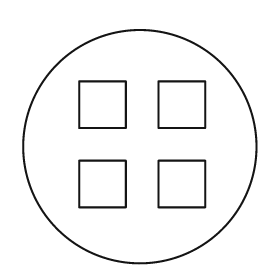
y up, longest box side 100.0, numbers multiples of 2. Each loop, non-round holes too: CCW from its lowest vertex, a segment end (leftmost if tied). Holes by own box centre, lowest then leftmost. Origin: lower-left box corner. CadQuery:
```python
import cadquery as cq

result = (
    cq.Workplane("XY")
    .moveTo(50.0, 50.0)
    .circle(50.0)
    .moveTo(24.0, 24.0)
    .lineTo(44.0, 24.0)
    .lineTo(44.0, 44.0)
    .lineTo(24.0, 44.0)
    .close()
    .moveTo(58.0, 24.0)
    .lineTo(78.0, 24.0)
    .lineTo(78.0, 44.0)
    .lineTo(58.0, 44.0)
    .close()
    .moveTo(24.0, 58.0)
    .lineTo(44.0, 58.0)
    .lineTo(44.0, 78.0)
    .lineTo(24.0, 78.0)
    .close()
    .moveTo(58.0, 58.0)
    .lineTo(78.0, 58.0)
    .lineTo(78.0, 78.0)
    .lineTo(58.0, 78.0)
    .close()
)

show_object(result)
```